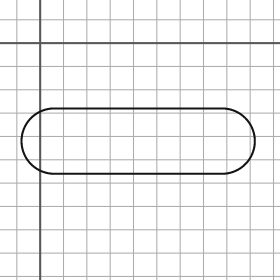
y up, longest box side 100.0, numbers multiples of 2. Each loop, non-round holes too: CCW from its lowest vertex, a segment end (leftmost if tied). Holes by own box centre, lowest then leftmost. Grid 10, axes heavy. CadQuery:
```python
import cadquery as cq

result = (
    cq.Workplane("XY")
    .moveTo(6.0, -56.0)
    .lineTo(78.0, -56.0)
    .threePointArc((92.0, -42.0), (78.0, -28.0))
    .lineTo(6.0, -28.0)
    .threePointArc((-8.0, -42.0), (6.0, -56.0))
    .close()
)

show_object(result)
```